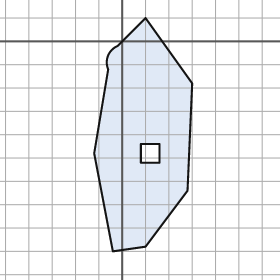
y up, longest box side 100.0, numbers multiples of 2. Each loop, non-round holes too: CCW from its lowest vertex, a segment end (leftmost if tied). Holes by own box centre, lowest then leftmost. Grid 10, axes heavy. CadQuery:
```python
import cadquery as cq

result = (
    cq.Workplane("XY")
    .moveTo(-4.0, -90.0)
    .lineTo(10.0, -88.0)
    .lineTo(28.0, -64.0)
    .lineTo(30.0, -18.0)
    .lineTo(10.0, 10.0)
    .lineTo(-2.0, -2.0)
    .threePointArc((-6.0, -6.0), (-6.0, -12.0))
    .lineTo(-12.0, -48.0)
    .close()
    .moveTo(8.0, -52.0)
    .lineTo(16.0, -52.0)
    .lineTo(16.0, -44.0)
    .lineTo(8.0, -44.0)
    .close()
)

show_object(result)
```